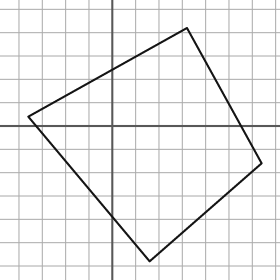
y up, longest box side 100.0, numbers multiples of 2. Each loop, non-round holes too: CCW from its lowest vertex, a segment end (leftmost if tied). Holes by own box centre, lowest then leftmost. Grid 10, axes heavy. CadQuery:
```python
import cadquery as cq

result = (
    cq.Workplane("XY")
    .moveTo(16.0, -58.0)
    .lineTo(64.0, -16.0)
    .lineTo(32.0, 42.0)
    .lineTo(-36.0, 4.0)
    .close()
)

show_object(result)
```